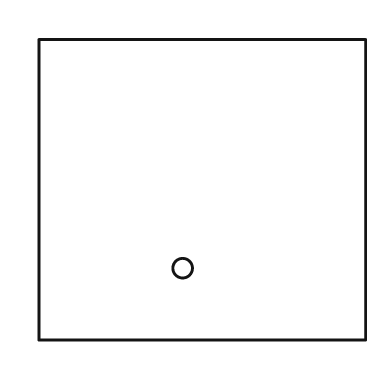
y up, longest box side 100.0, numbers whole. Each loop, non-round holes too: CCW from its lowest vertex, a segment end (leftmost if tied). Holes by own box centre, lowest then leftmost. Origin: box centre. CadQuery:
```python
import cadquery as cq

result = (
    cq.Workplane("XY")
    .moveTo(-50.0, -46.0)
    .lineTo(50.0, -46.0)
    .lineTo(50.0, 46.0)
    .lineTo(-50.0, 46.0)
    .close()
    .moveTo(-6.0, -24.0)
    .circle(3.0)
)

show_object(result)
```